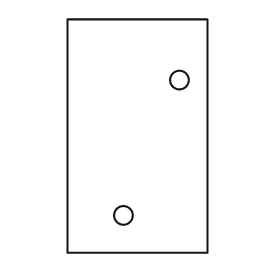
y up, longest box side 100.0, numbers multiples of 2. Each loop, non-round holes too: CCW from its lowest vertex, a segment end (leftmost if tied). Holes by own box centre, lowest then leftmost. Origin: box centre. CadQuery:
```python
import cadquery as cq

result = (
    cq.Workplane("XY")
    .moveTo(-30.0, -50.0)
    .lineTo(30.0, -50.0)
    .lineTo(30.0, 50.0)
    .lineTo(-30.0, 50.0)
    .close()
    .moveTo(-6.0, -34.0)
    .circle(4.0)
    .moveTo(18.0, 24.0)
    .circle(4.0)
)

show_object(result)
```